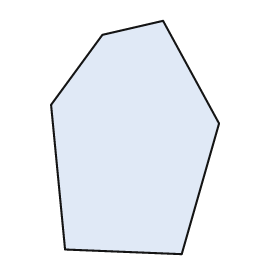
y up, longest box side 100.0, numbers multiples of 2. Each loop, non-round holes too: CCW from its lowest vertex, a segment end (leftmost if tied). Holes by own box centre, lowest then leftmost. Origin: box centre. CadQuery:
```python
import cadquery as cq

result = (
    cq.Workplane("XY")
    .moveTo(20.0, -50.0)
    .lineTo(36.0, 6.0)
    .lineTo(12.0, 50.0)
    .lineTo(-14.0, 44.0)
    .lineTo(-36.0, 14.0)
    .lineTo(-30.0, -48.0)
    .close()
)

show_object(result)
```